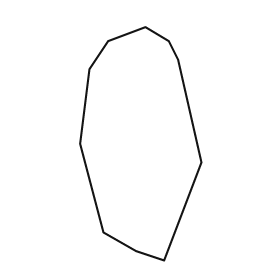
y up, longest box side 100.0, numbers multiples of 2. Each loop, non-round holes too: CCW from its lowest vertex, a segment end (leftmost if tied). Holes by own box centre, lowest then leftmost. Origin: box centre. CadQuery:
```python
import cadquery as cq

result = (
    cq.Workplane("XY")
    .moveTo(10.0, -50.0)
    .lineTo(26.0, -8.0)
    .lineTo(16.0, 36.0)
    .lineTo(12.0, 44.0)
    .lineTo(2.0, 50.0)
    .lineTo(-14.0, 44.0)
    .lineTo(-22.0, 32.0)
    .lineTo(-26.0, 0.0)
    .lineTo(-16.0, -38.0)
    .lineTo(-2.0, -46.0)
    .close()
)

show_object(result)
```